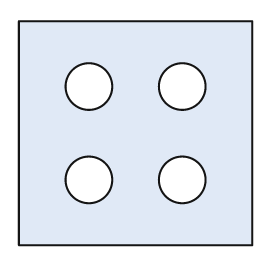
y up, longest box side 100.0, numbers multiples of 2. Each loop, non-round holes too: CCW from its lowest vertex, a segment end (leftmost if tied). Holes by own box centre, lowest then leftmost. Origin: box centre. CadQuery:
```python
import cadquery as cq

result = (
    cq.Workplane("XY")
    .moveTo(-50.0, -48.0)
    .lineTo(50.0, -48.0)
    .lineTo(50.0, 48.0)
    .lineTo(-50.0, 48.0)
    .close()
    .moveTo(-20.0, -20.0)
    .circle(10.0)
    .moveTo(20.0, -20.0)
    .circle(10.0)
    .moveTo(-20.0, 20.0)
    .circle(10.0)
    .moveTo(20.0, 20.0)
    .circle(10.0)
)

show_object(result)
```